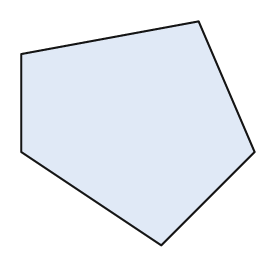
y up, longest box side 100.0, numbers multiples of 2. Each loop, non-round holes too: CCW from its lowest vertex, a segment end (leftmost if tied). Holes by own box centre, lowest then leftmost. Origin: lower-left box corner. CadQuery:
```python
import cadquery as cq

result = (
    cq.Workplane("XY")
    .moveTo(60.0, 0.0)
    .lineTo(100.0, 40.0)
    .lineTo(76.0, 96.0)
    .lineTo(0.0, 82.0)
    .lineTo(0.0, 40.0)
    .close()
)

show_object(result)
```